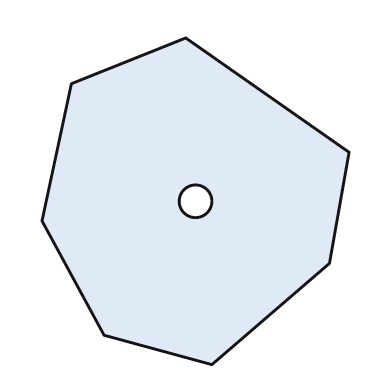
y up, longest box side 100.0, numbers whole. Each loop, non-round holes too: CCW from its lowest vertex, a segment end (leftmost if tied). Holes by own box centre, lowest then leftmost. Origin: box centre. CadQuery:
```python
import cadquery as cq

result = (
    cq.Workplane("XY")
    .moveTo(5.0, -50.0)
    .lineTo(41.0, -19.0)
    .lineTo(47.0, 15.0)
    .lineTo(-3.0, 50.0)
    .lineTo(-38.0, 36.0)
    .lineTo(-47.0, -6.0)
    .lineTo(-28.0, -41.0)
    .close()
    .moveTo(0.0, 0.0)
    .circle(5.0)
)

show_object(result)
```